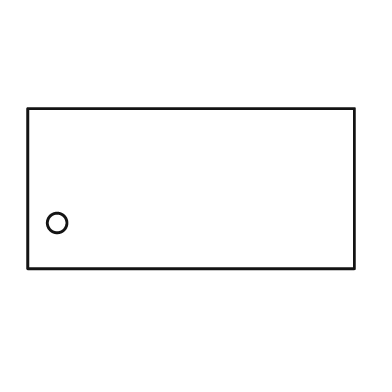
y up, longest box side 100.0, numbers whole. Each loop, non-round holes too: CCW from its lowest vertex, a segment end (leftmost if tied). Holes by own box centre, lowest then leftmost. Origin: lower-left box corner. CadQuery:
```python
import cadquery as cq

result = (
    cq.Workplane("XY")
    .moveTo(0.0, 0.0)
    .lineTo(100.0, 0.0)
    .lineTo(100.0, 49.0)
    .lineTo(0.0, 49.0)
    .close()
    .moveTo(9.0, 14.0)
    .circle(3.0)
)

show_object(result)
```